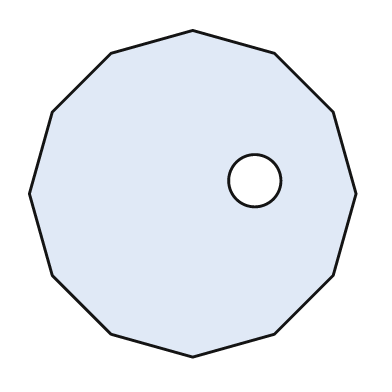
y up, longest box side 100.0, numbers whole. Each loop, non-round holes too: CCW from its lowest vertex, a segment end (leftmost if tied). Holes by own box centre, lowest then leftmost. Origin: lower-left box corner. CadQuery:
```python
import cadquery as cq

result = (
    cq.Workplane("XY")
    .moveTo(50.0, 0.0)
    .lineTo(75.0, 7.0)
    .lineTo(93.0, 25.0)
    .lineTo(100.0, 50.0)
    .lineTo(93.0, 75.0)
    .lineTo(75.0, 93.0)
    .lineTo(50.0, 100.0)
    .lineTo(25.0, 93.0)
    .lineTo(7.0, 75.0)
    .lineTo(0.0, 50.0)
    .lineTo(7.0, 25.0)
    .lineTo(25.0, 7.0)
    .close()
    .moveTo(69.0, 54.0)
    .circle(8.0)
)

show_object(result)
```